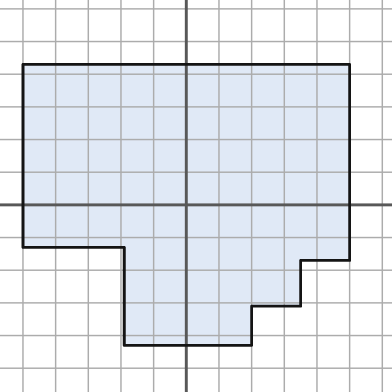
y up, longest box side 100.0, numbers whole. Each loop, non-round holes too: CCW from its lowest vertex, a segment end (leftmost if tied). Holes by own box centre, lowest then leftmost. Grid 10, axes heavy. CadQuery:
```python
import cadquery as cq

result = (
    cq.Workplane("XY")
    .moveTo(-19.0, -43.0)
    .lineTo(20.0, -43.0)
    .lineTo(20.0, -31.0)
    .lineTo(35.0, -31.0)
    .lineTo(35.0, -17.0)
    .lineTo(50.0, -17.0)
    .lineTo(50.0, 43.0)
    .lineTo(-50.0, 43.0)
    .lineTo(-50.0, -13.0)
    .lineTo(-19.0, -13.0)
    .close()
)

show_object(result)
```